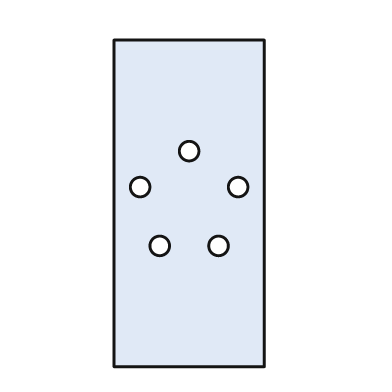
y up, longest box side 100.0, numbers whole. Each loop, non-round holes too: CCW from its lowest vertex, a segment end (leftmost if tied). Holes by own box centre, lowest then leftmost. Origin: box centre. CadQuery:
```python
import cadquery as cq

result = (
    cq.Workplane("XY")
    .moveTo(-23.0, -50.0)
    .lineTo(23.0, -50.0)
    .lineTo(23.0, 50.0)
    .lineTo(-23.0, 50.0)
    .close()
    .moveTo(-9.0, -13.0)
    .circle(3.0)
    .moveTo(9.0, -13.0)
    .circle(3.0)
    .moveTo(-15.0, 5.0)
    .circle(3.0)
    .moveTo(15.0, 5.0)
    .circle(3.0)
    .moveTo(0.0, 16.0)
    .circle(3.0)
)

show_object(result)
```